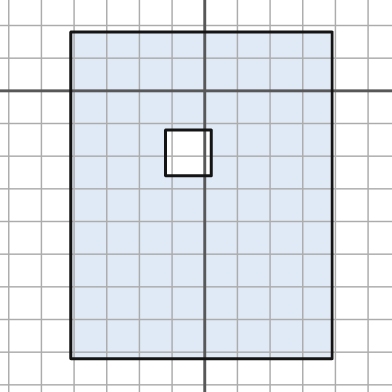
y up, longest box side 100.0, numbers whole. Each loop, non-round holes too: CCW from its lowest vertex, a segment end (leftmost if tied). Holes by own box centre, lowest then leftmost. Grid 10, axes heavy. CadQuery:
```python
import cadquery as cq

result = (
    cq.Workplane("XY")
    .moveTo(-41.0, -82.0)
    .lineTo(39.0, -82.0)
    .lineTo(39.0, 18.0)
    .lineTo(-41.0, 18.0)
    .close()
    .moveTo(-12.0, -26.0)
    .lineTo(2.0, -26.0)
    .lineTo(2.0, -12.0)
    .lineTo(-12.0, -12.0)
    .close()
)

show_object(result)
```